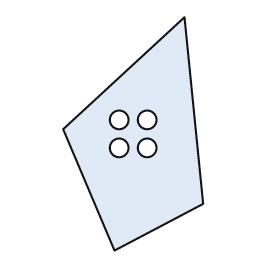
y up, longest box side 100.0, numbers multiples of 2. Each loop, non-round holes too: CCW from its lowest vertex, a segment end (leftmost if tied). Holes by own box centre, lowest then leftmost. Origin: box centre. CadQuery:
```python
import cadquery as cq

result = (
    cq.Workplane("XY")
    .moveTo(-8.0, -50.0)
    .lineTo(30.0, -30.0)
    .lineTo(22.0, 50.0)
    .lineTo(-30.0, 2.0)
    .close()
    .moveTo(-6.0, -6.0)
    .circle(4.0)
    .moveTo(6.0, -6.0)
    .circle(4.0)
    .moveTo(-6.0, 6.0)
    .circle(4.0)
    .moveTo(6.0, 6.0)
    .circle(4.0)
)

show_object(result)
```